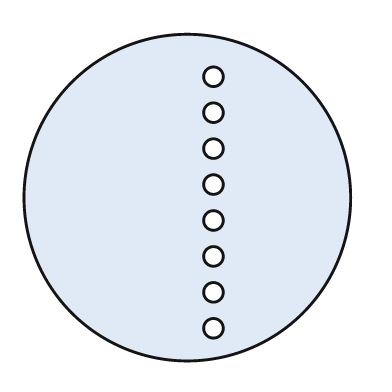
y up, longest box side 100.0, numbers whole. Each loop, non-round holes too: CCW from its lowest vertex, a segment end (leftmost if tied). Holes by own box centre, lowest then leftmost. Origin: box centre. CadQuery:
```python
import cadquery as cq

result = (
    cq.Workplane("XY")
    .moveTo(0.0, 0.0)
    .circle(50.0)
    .moveTo(8.0, -40.0)
    .circle(3.0)
    .moveTo(8.0, -29.0)
    .circle(3.0)
    .moveTo(8.0, -18.0)
    .circle(3.0)
    .moveTo(8.0, -7.0)
    .circle(3.0)
    .moveTo(8.0, 4.0)
    .circle(3.0)
    .moveTo(8.0, 15.0)
    .circle(3.0)
    .moveTo(8.0, 26.0)
    .circle(3.0)
    .moveTo(8.0, 37.0)
    .circle(3.0)
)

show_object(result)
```